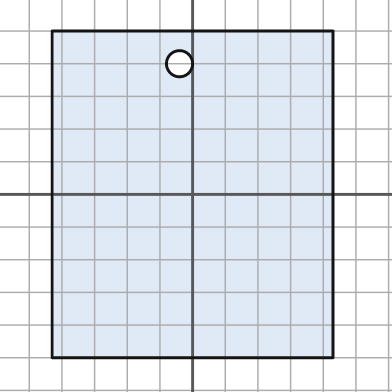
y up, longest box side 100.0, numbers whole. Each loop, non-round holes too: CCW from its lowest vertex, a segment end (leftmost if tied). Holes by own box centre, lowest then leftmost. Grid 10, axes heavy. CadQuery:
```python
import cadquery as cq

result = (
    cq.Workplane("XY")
    .moveTo(-43.0, -50.0)
    .lineTo(43.0, -50.0)
    .lineTo(43.0, 50.0)
    .lineTo(-43.0, 50.0)
    .close()
    .moveTo(-4.0, 40.0)
    .circle(4.0)
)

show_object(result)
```